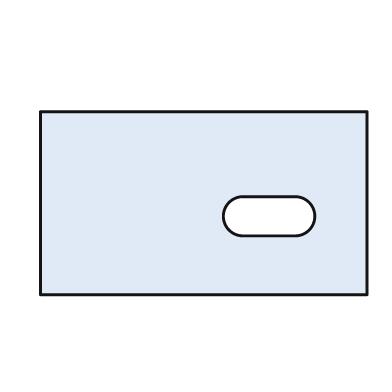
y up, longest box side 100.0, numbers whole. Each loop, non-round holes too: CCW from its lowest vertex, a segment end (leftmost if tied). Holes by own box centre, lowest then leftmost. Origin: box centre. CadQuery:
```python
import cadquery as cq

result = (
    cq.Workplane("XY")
    .moveTo(-50.0, -28.0)
    .lineTo(50.0, -28.0)
    .lineTo(50.0, 28.0)
    .lineTo(-50.0, 28.0)
    .close()
    .moveTo(12.0, -10.0)
    .lineTo(28.0, -10.0)
    .threePointArc((34.0, -4.0), (28.0, 2.0))
    .lineTo(12.0, 2.0)
    .threePointArc((6.0, -4.0), (12.0, -10.0))
    .close()
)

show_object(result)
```